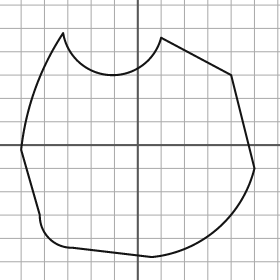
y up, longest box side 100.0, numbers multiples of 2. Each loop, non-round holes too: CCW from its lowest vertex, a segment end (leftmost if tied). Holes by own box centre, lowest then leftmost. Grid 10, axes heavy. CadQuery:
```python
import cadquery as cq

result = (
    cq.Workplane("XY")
    .moveTo(6.0, -48.0)
    .threePointArc((34.0, -36.0), (50.0, -10.0))
    .lineTo(40.0, 30.0)
    .lineTo(10.0, 46.0)
    .threePointArc((-12.0, 30.0), (-32.0, 48.0))
    .threePointArc((-44.0, 24.0), (-50.0, -2.0))
    .lineTo(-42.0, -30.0)
    .threePointArc((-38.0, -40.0), (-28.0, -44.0))
    .close()
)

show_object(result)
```